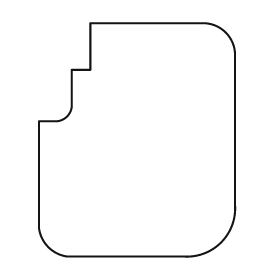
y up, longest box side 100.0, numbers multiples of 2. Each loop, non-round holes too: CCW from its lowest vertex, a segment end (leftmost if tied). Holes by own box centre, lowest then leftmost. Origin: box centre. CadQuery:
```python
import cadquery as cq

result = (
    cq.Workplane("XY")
    .moveTo(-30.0, -50.0)
    .lineTo(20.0, -50.0)
    .threePointArc((36.0, -44.0), (42.0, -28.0))
    .lineTo(42.0, 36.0)
    .threePointArc((38.0, 46.0), (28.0, 50.0))
    .lineTo(-20.0, 50.0)
    .lineTo(-20.0, 30.0)
    .lineTo(-28.0, 30.0)
    .lineTo(-28.0, 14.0)
    .threePointArc((-30.0, 10.0), (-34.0, 8.0))
    .lineTo(-42.0, 8.0)
    .lineTo(-42.0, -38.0)
    .threePointArc((-38.0, -46.0), (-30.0, -50.0))
    .close()
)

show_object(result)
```